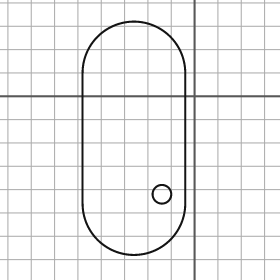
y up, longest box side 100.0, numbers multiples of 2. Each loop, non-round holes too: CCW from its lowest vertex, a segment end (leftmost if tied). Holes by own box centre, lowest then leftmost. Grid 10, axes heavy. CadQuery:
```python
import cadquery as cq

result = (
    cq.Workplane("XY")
    .moveTo(-48.0, -46.0)
    .threePointArc((-26.0, -68.0), (-4.0, -46.0))
    .lineTo(-4.0, 10.0)
    .threePointArc((-26.0, 32.0), (-48.0, 10.0))
    .close()
    .moveTo(-14.0, -42.0)
    .circle(4.0)
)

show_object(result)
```